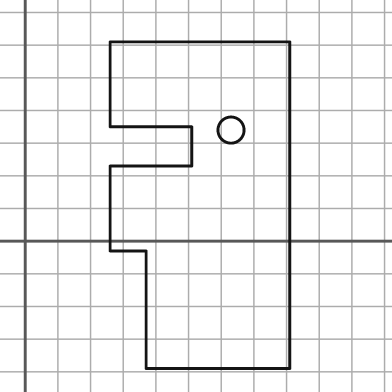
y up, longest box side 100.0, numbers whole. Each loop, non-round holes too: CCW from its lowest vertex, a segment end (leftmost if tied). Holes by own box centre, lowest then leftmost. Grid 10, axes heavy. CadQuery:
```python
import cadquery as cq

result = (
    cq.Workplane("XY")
    .moveTo(37.0, -39.0)
    .lineTo(81.0, -39.0)
    .lineTo(81.0, 61.0)
    .lineTo(26.0, 61.0)
    .lineTo(26.0, 35.0)
    .lineTo(51.0, 35.0)
    .lineTo(51.0, 23.0)
    .lineTo(26.0, 23.0)
    .lineTo(26.0, -3.0)
    .lineTo(37.0, -3.0)
    .close()
    .moveTo(63.0, 34.0)
    .circle(4.0)
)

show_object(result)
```